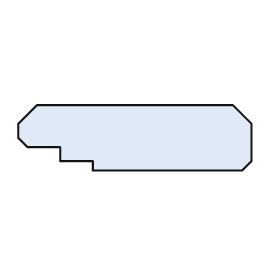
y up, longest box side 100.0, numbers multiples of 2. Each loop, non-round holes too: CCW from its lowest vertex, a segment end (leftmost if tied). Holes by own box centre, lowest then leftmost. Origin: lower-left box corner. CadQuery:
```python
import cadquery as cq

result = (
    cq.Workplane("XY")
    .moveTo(32.0, 0.0)
    .lineTo(96.0, 0.0)
    .lineTo(100.0, 4.0)
    .lineTo(100.0, 20.0)
    .lineTo(92.0, 28.0)
    .lineTo(8.0, 28.0)
    .lineTo(0.0, 20.0)
    .lineTo(0.0, 14.0)
    .lineTo(4.0, 10.0)
    .lineTo(18.0, 10.0)
    .lineTo(18.0, 4.0)
    .lineTo(32.0, 4.0)
    .close()
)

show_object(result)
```